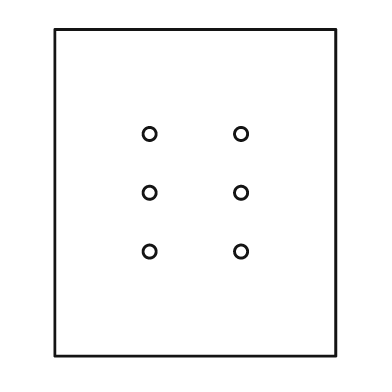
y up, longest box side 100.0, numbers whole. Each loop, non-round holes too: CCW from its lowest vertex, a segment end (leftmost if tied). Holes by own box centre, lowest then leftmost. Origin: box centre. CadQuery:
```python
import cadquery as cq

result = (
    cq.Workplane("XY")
    .moveTo(-43.0, -50.0)
    .lineTo(43.0, -50.0)
    .lineTo(43.0, 50.0)
    .lineTo(-43.0, 50.0)
    .close()
    .moveTo(-14.0, -18.0)
    .circle(2.0)
    .moveTo(14.0, -18.0)
    .circle(2.0)
    .moveTo(-14.0, 0.0)
    .circle(2.0)
    .moveTo(14.0, 0.0)
    .circle(2.0)
    .moveTo(-14.0, 18.0)
    .circle(2.0)
    .moveTo(14.0, 18.0)
    .circle(2.0)
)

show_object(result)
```